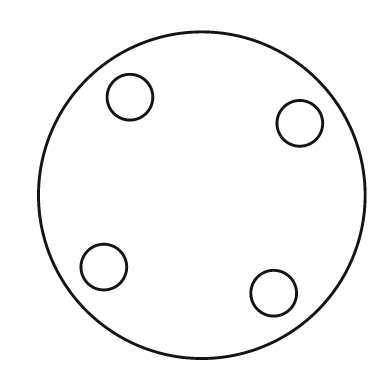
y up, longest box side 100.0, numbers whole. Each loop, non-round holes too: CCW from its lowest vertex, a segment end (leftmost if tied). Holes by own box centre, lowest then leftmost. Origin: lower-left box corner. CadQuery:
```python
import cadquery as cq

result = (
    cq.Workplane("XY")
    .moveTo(50.0, 50.0)
    .circle(50.0)
    .moveTo(72.0, 20.0)
    .circle(7.0)
    .moveTo(20.0, 28.0)
    .circle(7.0)
    .moveTo(80.0, 72.0)
    .circle(7.0)
    .moveTo(28.0, 80.0)
    .circle(7.0)
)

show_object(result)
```